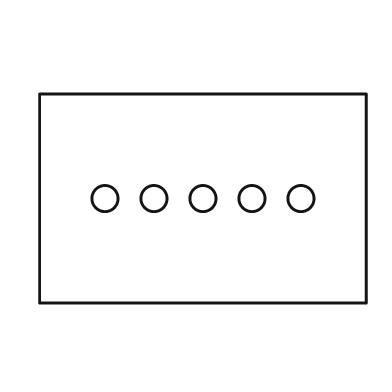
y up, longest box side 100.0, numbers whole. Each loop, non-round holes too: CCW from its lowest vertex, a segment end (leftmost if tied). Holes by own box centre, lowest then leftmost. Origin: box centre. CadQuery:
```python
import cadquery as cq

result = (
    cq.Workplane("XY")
    .moveTo(-50.0, -32.0)
    .lineTo(50.0, -32.0)
    .lineTo(50.0, 32.0)
    .lineTo(-50.0, 32.0)
    .close()
    .moveTo(-30.0, 0.0)
    .circle(4.0)
    .moveTo(-15.0, 0.0)
    .circle(4.0)
    .moveTo(0.0, 0.0)
    .circle(4.0)
    .moveTo(15.0, 0.0)
    .circle(4.0)
    .moveTo(30.0, 0.0)
    .circle(4.0)
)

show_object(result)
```